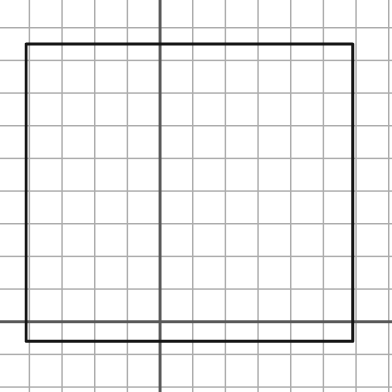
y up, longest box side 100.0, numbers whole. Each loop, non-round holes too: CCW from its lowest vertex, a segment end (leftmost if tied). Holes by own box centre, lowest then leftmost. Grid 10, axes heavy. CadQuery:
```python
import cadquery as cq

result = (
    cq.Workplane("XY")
    .moveTo(-41.0, -6.0)
    .lineTo(59.0, -6.0)
    .lineTo(59.0, 85.0)
    .lineTo(-41.0, 85.0)
    .close()
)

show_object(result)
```